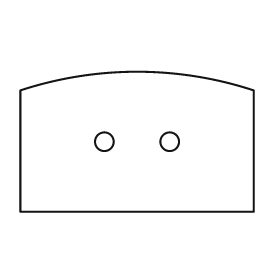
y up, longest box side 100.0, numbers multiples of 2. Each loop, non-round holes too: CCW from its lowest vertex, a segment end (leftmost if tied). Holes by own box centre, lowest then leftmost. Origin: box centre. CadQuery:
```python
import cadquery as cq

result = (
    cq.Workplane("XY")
    .moveTo(-50.0, -30.0)
    .lineTo(50.0, -30.0)
    .lineTo(50.0, 22.0)
    .threePointArc((0.0, 30.0), (-50.0, 22.0))
    .close()
    .moveTo(-14.0, 0.0)
    .circle(4.0)
    .moveTo(14.0, 0.0)
    .circle(4.0)
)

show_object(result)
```